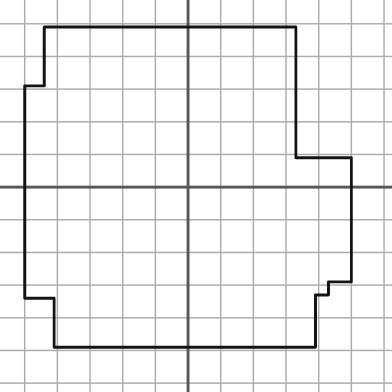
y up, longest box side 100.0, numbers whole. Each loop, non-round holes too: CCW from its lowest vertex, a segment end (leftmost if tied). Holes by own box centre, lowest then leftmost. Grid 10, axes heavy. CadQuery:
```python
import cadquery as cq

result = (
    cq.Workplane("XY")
    .moveTo(-41.0, -49.0)
    .lineTo(39.0, -49.0)
    .lineTo(39.0, -33.0)
    .lineTo(43.0, -33.0)
    .lineTo(43.0, -29.0)
    .lineTo(50.0, -29.0)
    .lineTo(50.0, 9.0)
    .lineTo(33.0, 9.0)
    .lineTo(33.0, 49.0)
    .lineTo(-44.0, 49.0)
    .lineTo(-44.0, 31.0)
    .lineTo(-50.0, 31.0)
    .lineTo(-50.0, -34.0)
    .lineTo(-41.0, -34.0)
    .close()
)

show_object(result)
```